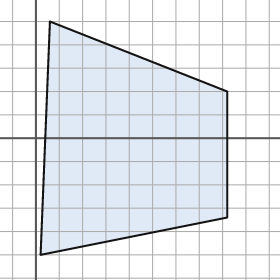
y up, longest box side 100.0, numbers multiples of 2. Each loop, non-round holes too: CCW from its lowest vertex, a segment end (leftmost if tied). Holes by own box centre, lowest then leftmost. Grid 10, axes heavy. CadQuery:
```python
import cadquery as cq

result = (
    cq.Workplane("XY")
    .moveTo(2.0, -50.0)
    .lineTo(82.0, -34.0)
    .lineTo(82.0, 20.0)
    .lineTo(6.0, 50.0)
    .close()
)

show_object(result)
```